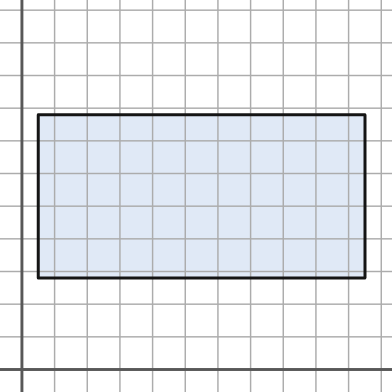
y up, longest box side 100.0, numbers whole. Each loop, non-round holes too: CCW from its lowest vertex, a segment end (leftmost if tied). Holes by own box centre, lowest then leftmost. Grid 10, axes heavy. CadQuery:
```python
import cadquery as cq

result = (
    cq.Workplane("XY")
    .moveTo(5.0, 28.0)
    .lineTo(105.0, 28.0)
    .lineTo(105.0, 78.0)
    .lineTo(5.0, 78.0)
    .close()
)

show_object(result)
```